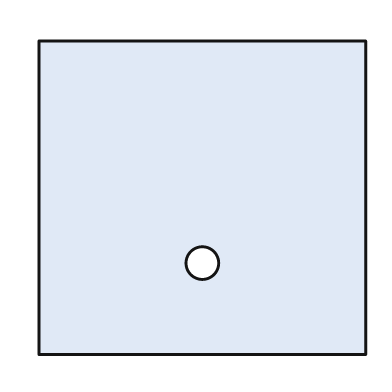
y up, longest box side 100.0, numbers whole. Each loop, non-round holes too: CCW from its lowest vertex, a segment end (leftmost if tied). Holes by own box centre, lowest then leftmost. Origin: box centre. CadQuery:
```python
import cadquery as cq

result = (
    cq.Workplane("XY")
    .moveTo(-50.0, -48.0)
    .lineTo(50.0, -48.0)
    .lineTo(50.0, 48.0)
    .lineTo(-50.0, 48.0)
    .close()
    .moveTo(0.0, -20.0)
    .circle(5.0)
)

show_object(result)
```